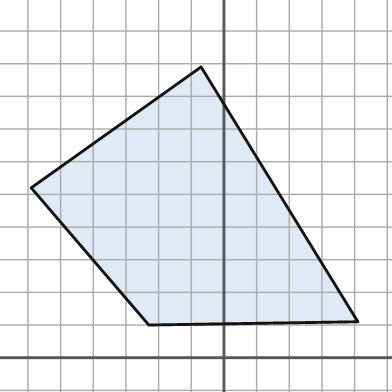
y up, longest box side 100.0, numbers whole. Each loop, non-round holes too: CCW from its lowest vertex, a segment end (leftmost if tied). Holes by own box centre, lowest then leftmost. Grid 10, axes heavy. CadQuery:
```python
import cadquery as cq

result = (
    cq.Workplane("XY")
    .moveTo(-23.0, 10.0)
    .lineTo(41.0, 11.0)
    .lineTo(-7.0, 89.0)
    .lineTo(-59.0, 52.0)
    .close()
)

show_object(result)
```